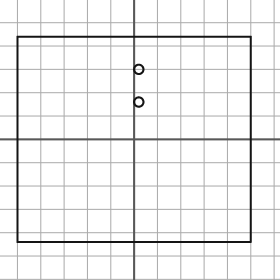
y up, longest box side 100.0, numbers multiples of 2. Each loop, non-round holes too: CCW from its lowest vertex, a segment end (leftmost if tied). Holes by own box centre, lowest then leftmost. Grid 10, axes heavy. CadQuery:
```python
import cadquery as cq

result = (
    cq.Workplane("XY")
    .moveTo(-50.0, -44.0)
    .lineTo(50.0, -44.0)
    .lineTo(50.0, 44.0)
    .lineTo(-50.0, 44.0)
    .close()
    .moveTo(2.0, 16.0)
    .circle(2.0)
    .moveTo(2.0, 30.0)
    .circle(2.0)
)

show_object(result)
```